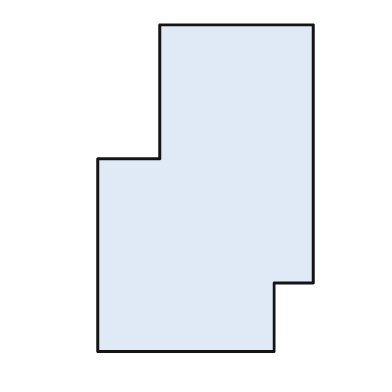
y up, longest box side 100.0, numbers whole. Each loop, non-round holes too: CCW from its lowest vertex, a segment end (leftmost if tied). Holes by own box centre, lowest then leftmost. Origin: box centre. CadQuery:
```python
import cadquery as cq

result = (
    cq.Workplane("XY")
    .moveTo(-33.0, -50.0)
    .lineTo(21.0, -50.0)
    .lineTo(21.0, -29.0)
    .lineTo(33.0, -29.0)
    .lineTo(33.0, 50.0)
    .lineTo(-14.0, 50.0)
    .lineTo(-14.0, 9.0)
    .lineTo(-33.0, 9.0)
    .close()
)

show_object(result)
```